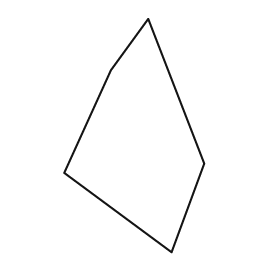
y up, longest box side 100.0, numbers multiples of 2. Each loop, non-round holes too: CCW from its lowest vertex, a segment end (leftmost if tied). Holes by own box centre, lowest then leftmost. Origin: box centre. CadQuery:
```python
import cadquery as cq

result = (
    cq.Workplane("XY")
    .moveTo(16.0, -50.0)
    .lineTo(30.0, -12.0)
    .lineTo(6.0, 50.0)
    .lineTo(-10.0, 28.0)
    .lineTo(-30.0, -16.0)
    .close()
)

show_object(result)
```